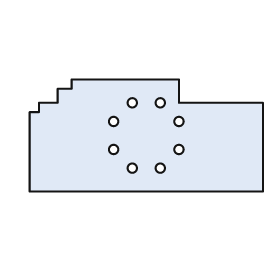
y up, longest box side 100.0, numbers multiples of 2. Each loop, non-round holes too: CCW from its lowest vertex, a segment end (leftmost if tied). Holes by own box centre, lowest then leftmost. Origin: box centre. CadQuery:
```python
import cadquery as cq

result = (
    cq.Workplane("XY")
    .moveTo(-50.0, -24.0)
    .lineTo(50.0, -24.0)
    .lineTo(50.0, 14.0)
    .lineTo(14.0, 14.0)
    .lineTo(14.0, 24.0)
    .lineTo(-32.0, 24.0)
    .lineTo(-32.0, 20.0)
    .lineTo(-38.0, 20.0)
    .lineTo(-38.0, 14.0)
    .lineTo(-46.0, 14.0)
    .lineTo(-46.0, 10.0)
    .lineTo(-50.0, 10.0)
    .close()
    .moveTo(-6.0, -14.0)
    .circle(2.0)
    .moveTo(6.0, -14.0)
    .circle(2.0)
    .moveTo(-14.0, -6.0)
    .circle(2.0)
    .moveTo(14.0, -6.0)
    .circle(2.0)
    .moveTo(-14.0, 6.0)
    .circle(2.0)
    .moveTo(14.0, 6.0)
    .circle(2.0)
    .moveTo(-6.0, 14.0)
    .circle(2.0)
    .moveTo(6.0, 14.0)
    .circle(2.0)
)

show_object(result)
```